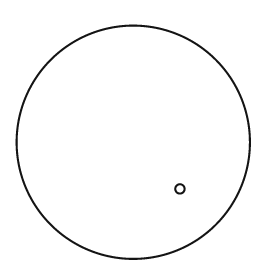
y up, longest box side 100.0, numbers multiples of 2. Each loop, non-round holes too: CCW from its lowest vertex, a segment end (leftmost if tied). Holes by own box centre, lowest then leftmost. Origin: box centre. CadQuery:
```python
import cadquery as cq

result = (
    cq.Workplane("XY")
    .moveTo(0.0, 0.0)
    .circle(50.0)
    .moveTo(20.0, -20.0)
    .circle(2.0)
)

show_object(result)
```